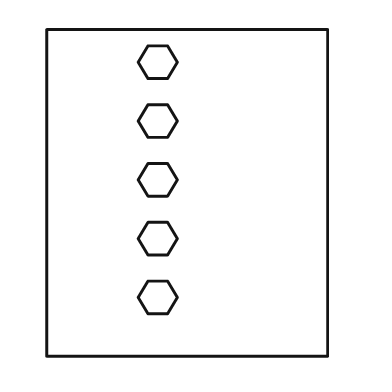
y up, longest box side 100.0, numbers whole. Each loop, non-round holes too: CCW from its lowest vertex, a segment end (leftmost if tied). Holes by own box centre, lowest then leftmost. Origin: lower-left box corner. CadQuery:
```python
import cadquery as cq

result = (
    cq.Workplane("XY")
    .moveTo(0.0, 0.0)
    .lineTo(86.0, 0.0)
    .lineTo(86.0, 100.0)
    .lineTo(0.0, 100.0)
    .close()
    .moveTo(31.0, 13.0)
    .lineTo(37.0, 13.0)
    .lineTo(40.0, 18.0)
    .lineTo(37.0, 23.0)
    .lineTo(31.0, 23.0)
    .lineTo(28.0, 18.0)
    .close()
    .moveTo(31.0, 31.0)
    .lineTo(37.0, 31.0)
    .lineTo(40.0, 36.0)
    .lineTo(37.0, 41.0)
    .lineTo(31.0, 41.0)
    .lineTo(28.0, 36.0)
    .close()
    .moveTo(31.0, 49.0)
    .lineTo(37.0, 49.0)
    .lineTo(40.0, 54.0)
    .lineTo(37.0, 59.0)
    .lineTo(31.0, 59.0)
    .lineTo(28.0, 54.0)
    .close()
    .moveTo(31.0, 67.0)
    .lineTo(37.0, 67.0)
    .lineTo(40.0, 72.0)
    .lineTo(37.0, 77.0)
    .lineTo(31.0, 77.0)
    .lineTo(28.0, 72.0)
    .close()
    .moveTo(31.0, 85.0)
    .lineTo(37.0, 85.0)
    .lineTo(40.0, 90.0)
    .lineTo(37.0, 95.0)
    .lineTo(31.0, 95.0)
    .lineTo(28.0, 90.0)
    .close()
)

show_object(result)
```